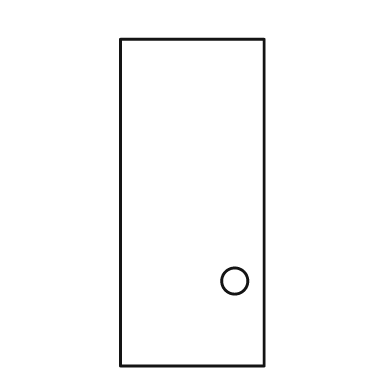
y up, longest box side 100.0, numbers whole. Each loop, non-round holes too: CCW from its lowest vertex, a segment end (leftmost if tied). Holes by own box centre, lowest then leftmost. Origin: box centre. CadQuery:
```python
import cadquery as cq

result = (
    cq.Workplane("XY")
    .moveTo(-22.0, -50.0)
    .lineTo(22.0, -50.0)
    .lineTo(22.0, 50.0)
    .lineTo(-22.0, 50.0)
    .close()
    .moveTo(13.0, -24.0)
    .circle(4.0)
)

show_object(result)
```